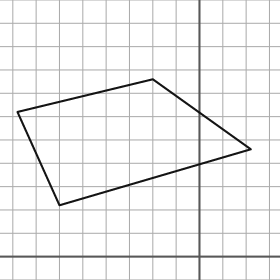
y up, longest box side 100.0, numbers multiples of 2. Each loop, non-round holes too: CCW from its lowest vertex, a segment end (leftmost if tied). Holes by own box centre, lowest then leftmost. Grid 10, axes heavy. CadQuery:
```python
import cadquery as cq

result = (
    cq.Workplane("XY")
    .moveTo(-60.0, 22.0)
    .lineTo(22.0, 46.0)
    .lineTo(-20.0, 76.0)
    .lineTo(-78.0, 62.0)
    .close()
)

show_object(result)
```